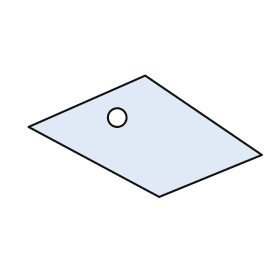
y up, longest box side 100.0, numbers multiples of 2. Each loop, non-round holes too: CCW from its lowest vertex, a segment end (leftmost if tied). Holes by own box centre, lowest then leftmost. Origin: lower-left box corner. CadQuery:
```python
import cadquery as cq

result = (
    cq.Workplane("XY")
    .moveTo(56.0, 0.0)
    .lineTo(100.0, 18.0)
    .lineTo(50.0, 52.0)
    .lineTo(0.0, 30.0)
    .close()
    .moveTo(38.0, 34.0)
    .circle(4.0)
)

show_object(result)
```